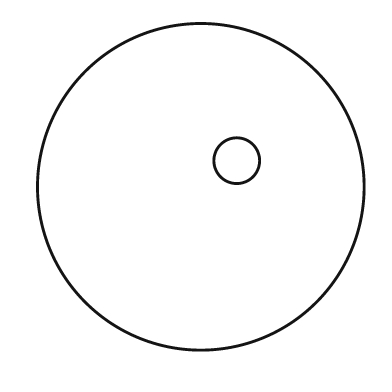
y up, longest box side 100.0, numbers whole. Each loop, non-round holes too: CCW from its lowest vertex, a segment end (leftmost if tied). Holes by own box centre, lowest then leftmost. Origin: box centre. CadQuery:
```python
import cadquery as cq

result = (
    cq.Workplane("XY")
    .moveTo(0.0, 0.0)
    .circle(50.0)
    .moveTo(11.0, 8.0)
    .circle(7.0)
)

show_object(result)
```